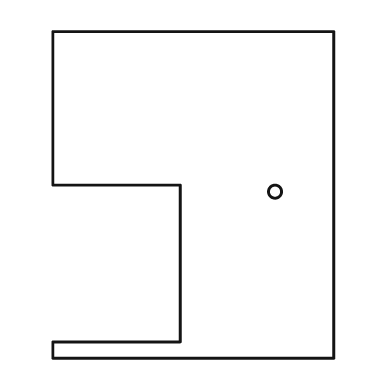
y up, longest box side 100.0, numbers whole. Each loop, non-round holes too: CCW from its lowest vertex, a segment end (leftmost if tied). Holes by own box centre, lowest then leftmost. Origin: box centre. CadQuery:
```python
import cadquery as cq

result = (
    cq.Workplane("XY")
    .moveTo(-43.0, -50.0)
    .lineTo(43.0, -50.0)
    .lineTo(43.0, 50.0)
    .lineTo(-43.0, 50.0)
    .lineTo(-43.0, 3.0)
    .lineTo(-4.0, 3.0)
    .lineTo(-4.0, -45.0)
    .lineTo(-43.0, -45.0)
    .close()
    .moveTo(25.0, 1.0)
    .circle(2.0)
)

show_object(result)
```